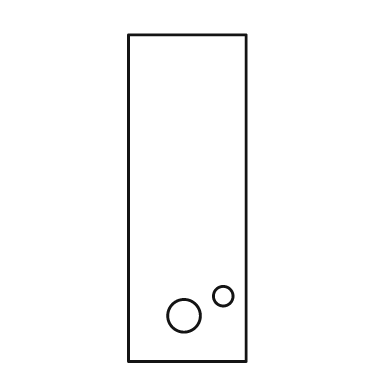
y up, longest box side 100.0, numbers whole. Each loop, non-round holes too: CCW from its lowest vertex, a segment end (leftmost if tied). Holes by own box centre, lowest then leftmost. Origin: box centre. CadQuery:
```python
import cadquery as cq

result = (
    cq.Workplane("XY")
    .moveTo(-18.0, -50.0)
    .lineTo(18.0, -50.0)
    .lineTo(18.0, 50.0)
    .lineTo(-18.0, 50.0)
    .close()
    .moveTo(-1.0, -36.0)
    .circle(5.0)
    .moveTo(11.0, -30.0)
    .circle(3.0)
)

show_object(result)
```